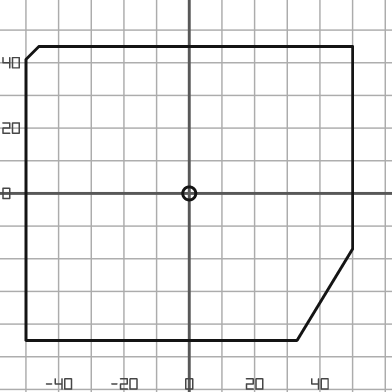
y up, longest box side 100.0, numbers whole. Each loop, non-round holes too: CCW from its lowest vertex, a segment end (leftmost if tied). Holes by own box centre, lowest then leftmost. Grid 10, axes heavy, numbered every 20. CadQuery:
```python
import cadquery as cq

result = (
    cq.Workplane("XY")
    .moveTo(-50.0, -45.0)
    .lineTo(33.0, -45.0)
    .lineTo(50.0, -17.0)
    .lineTo(50.0, 45.0)
    .lineTo(-46.0, 45.0)
    .lineTo(-50.0, 41.0)
    .close()
    .moveTo(0.0, 0.0)
    .circle(2.0)
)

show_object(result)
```